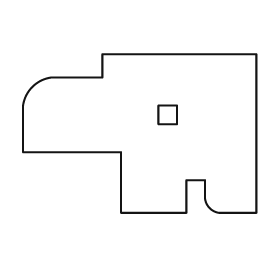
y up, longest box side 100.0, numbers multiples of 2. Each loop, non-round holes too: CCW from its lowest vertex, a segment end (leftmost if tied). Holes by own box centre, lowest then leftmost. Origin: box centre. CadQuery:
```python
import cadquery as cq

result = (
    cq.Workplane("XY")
    .moveTo(-8.0, -34.0)
    .lineTo(20.0, -34.0)
    .lineTo(20.0, -20.0)
    .lineTo(28.0, -20.0)
    .lineTo(28.0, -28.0)
    .threePointArc((30.0, -32.0), (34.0, -34.0))
    .lineTo(50.0, -34.0)
    .lineTo(50.0, 34.0)
    .lineTo(-16.0, 34.0)
    .lineTo(-16.0, 24.0)
    .lineTo(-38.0, 24.0)
    .threePointArc((-46.0, 20.0), (-50.0, 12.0))
    .lineTo(-50.0, -8.0)
    .lineTo(-8.0, -8.0)
    .close()
    .moveTo(8.0, 4.0)
    .lineTo(16.0, 4.0)
    .lineTo(16.0, 12.0)
    .lineTo(8.0, 12.0)
    .close()
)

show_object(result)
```